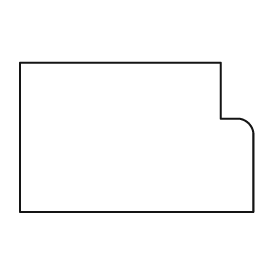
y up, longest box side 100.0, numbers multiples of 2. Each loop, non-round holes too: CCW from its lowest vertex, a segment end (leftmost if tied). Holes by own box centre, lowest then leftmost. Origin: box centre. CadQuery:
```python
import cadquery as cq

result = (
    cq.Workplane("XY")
    .moveTo(-50.0, -32.0)
    .lineTo(50.0, -32.0)
    .lineTo(50.0, 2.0)
    .threePointArc((48.0, 6.0), (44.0, 8.0))
    .lineTo(36.0, 8.0)
    .lineTo(36.0, 32.0)
    .lineTo(-50.0, 32.0)
    .close()
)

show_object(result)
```